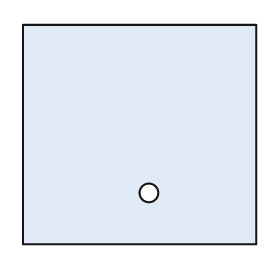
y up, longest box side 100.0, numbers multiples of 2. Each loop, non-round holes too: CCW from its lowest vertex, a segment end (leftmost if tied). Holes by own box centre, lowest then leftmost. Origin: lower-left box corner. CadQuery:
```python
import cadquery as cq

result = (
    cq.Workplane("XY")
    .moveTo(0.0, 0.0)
    .lineTo(100.0, 0.0)
    .lineTo(100.0, 94.0)
    .lineTo(0.0, 94.0)
    .close()
    .moveTo(54.0, 22.0)
    .circle(4.0)
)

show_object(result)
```